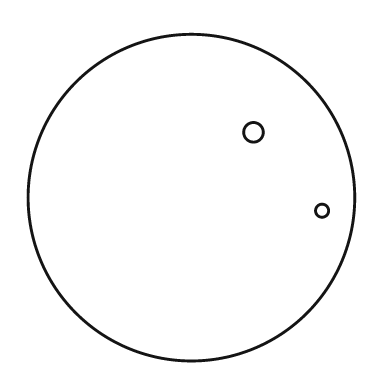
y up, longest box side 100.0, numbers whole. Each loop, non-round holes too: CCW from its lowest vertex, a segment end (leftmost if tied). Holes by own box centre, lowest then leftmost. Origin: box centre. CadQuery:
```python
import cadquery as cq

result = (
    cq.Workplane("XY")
    .moveTo(0.0, 0.0)
    .circle(50.0)
    .moveTo(40.0, -4.0)
    .circle(2.0)
    .moveTo(19.0, 20.0)
    .circle(3.0)
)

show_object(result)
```